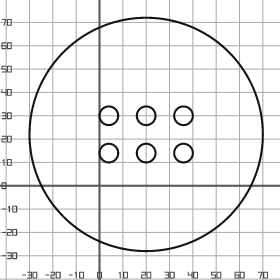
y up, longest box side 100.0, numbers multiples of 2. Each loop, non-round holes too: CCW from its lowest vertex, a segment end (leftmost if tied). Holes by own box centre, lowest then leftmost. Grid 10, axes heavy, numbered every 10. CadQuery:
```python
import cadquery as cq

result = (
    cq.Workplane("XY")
    .moveTo(20.0, 22.0)
    .circle(50.0)
    .moveTo(4.0, 14.0)
    .circle(4.0)
    .moveTo(20.0, 14.0)
    .circle(4.0)
    .moveTo(36.0, 14.0)
    .circle(4.0)
    .moveTo(4.0, 30.0)
    .circle(4.0)
    .moveTo(20.0, 30.0)
    .circle(4.0)
    .moveTo(36.0, 30.0)
    .circle(4.0)
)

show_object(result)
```